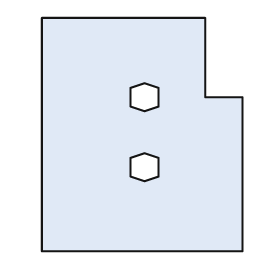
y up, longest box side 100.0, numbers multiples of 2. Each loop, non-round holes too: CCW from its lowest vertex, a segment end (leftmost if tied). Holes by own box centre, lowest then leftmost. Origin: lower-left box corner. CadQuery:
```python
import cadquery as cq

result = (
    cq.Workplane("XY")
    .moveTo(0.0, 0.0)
    .lineTo(86.0, 0.0)
    .lineTo(86.0, 66.0)
    .lineTo(70.0, 66.0)
    .lineTo(70.0, 100.0)
    .lineTo(0.0, 100.0)
    .close()
    .moveTo(44.0, 30.0)
    .lineTo(50.0, 32.0)
    .lineTo(50.0, 40.0)
    .lineTo(44.0, 42.0)
    .lineTo(38.0, 40.0)
    .lineTo(38.0, 32.0)
    .close()
    .moveTo(44.0, 60.0)
    .lineTo(50.0, 62.0)
    .lineTo(50.0, 70.0)
    .lineTo(44.0, 72.0)
    .lineTo(38.0, 70.0)
    .lineTo(38.0, 62.0)
    .close()
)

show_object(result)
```